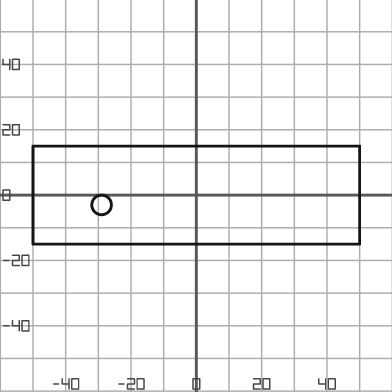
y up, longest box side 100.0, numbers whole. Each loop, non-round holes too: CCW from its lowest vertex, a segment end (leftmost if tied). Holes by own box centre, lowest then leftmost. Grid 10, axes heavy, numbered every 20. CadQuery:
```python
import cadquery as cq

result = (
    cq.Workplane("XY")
    .moveTo(-50.0, -15.0)
    .lineTo(50.0, -15.0)
    .lineTo(50.0, 15.0)
    .lineTo(-50.0, 15.0)
    .close()
    .moveTo(-29.0, -3.0)
    .circle(3.0)
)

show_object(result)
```